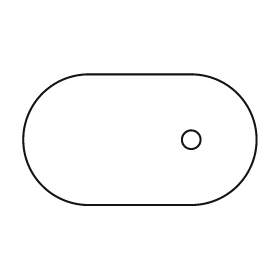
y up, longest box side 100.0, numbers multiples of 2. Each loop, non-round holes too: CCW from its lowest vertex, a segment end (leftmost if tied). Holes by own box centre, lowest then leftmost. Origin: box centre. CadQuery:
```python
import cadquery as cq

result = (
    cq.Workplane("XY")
    .moveTo(-22.0, -28.0)
    .lineTo(22.0, -28.0)
    .threePointArc((50.0, 0.0), (22.0, 28.0))
    .lineTo(-22.0, 28.0)
    .threePointArc((-50.0, 0.0), (-22.0, -28.0))
    .close()
    .moveTo(22.0, 0.0)
    .circle(4.0)
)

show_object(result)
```